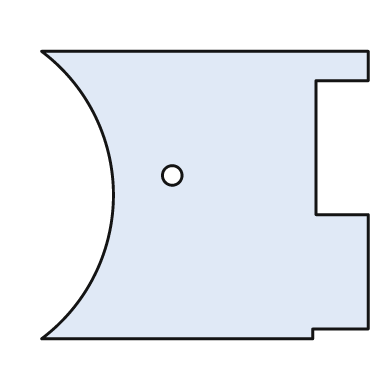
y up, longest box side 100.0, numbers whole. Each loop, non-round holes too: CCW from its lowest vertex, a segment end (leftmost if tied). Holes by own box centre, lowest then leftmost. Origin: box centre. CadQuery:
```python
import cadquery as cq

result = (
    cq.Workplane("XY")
    .moveTo(-50.0, -44.0)
    .lineTo(33.0, -44.0)
    .lineTo(33.0, -41.0)
    .lineTo(50.0, -41.0)
    .lineTo(50.0, -6.0)
    .lineTo(34.0, -6.0)
    .lineTo(34.0, 35.0)
    .lineTo(50.0, 35.0)
    .lineTo(50.0, 44.0)
    .lineTo(-50.0, 44.0)
    .threePointArc((-28.0, 0.0), (-50.0, -44.0))
    .close()
    .moveTo(-10.0, 6.0)
    .circle(3.0)
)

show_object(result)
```